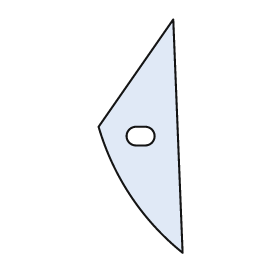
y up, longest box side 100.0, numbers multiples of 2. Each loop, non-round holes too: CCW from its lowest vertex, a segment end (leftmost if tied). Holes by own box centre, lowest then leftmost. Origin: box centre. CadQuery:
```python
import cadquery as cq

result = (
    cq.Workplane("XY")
    .moveTo(18.0, -50.0)
    .lineTo(14.0, 50.0)
    .lineTo(-18.0, 4.0)
    .threePointArc((-4.0, -26.0), (18.0, -50.0))
    .close()
    .moveTo(-2.0, -4.0)
    .lineTo(2.0, -4.0)
    .threePointArc((6.0, 0.0), (2.0, 4.0))
    .lineTo(-2.0, 4.0)
    .threePointArc((-6.0, 0.0), (-2.0, -4.0))
    .close()
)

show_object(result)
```